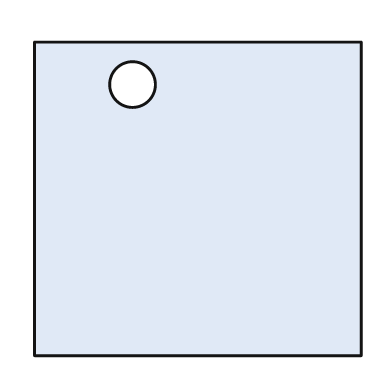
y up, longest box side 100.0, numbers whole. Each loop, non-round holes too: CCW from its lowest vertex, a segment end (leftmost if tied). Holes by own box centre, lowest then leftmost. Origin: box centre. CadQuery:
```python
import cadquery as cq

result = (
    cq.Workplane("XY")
    .moveTo(-50.0, -48.0)
    .lineTo(50.0, -48.0)
    .lineTo(50.0, 48.0)
    .lineTo(-50.0, 48.0)
    .close()
    .moveTo(-20.0, 35.0)
    .circle(7.0)
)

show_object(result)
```